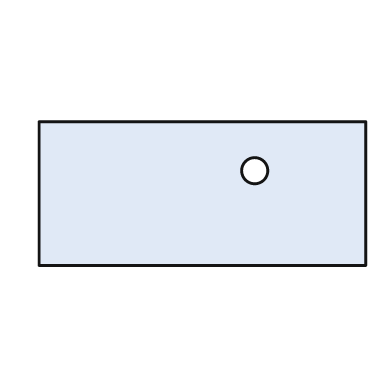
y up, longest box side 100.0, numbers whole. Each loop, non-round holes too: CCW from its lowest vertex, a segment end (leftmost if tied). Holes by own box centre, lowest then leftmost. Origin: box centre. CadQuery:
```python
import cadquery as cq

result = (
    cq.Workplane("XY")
    .moveTo(-50.0, -22.0)
    .lineTo(50.0, -22.0)
    .lineTo(50.0, 22.0)
    .lineTo(-50.0, 22.0)
    .close()
    .moveTo(16.0, 7.0)
    .circle(4.0)
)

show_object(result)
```